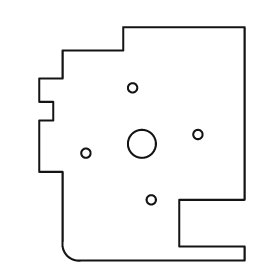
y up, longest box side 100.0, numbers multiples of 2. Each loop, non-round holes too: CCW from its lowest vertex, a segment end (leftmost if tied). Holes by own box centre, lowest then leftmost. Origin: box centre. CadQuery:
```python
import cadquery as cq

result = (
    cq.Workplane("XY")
    .moveTo(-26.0, -50.0)
    .lineTo(44.0, -50.0)
    .lineTo(44.0, -44.0)
    .lineTo(16.0, -44.0)
    .lineTo(16.0, -24.0)
    .lineTo(44.0, -24.0)
    .lineTo(44.0, 50.0)
    .lineTo(-8.0, 50.0)
    .lineTo(-8.0, 40.0)
    .lineTo(-34.0, 40.0)
    .lineTo(-34.0, 28.0)
    .lineTo(-44.0, 28.0)
    .lineTo(-44.0, 18.0)
    .lineTo(-38.0, 18.0)
    .lineTo(-38.0, 10.0)
    .lineTo(-44.0, 10.0)
    .lineTo(-44.0, -12.0)
    .lineTo(-34.0, -12.0)
    .lineTo(-34.0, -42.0)
    .threePointArc((-32.0, -48.0), (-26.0, -50.0))
    .close()
    .moveTo(4.0, -24.0)
    .circle(2.0)
    .moveTo(-24.0, -4.0)
    .circle(2.0)
    .moveTo(0.0, 0.0)
    .circle(6.0)
    .moveTo(24.0, 4.0)
    .circle(2.0)
    .moveTo(-4.0, 24.0)
    .circle(2.0)
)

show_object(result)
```